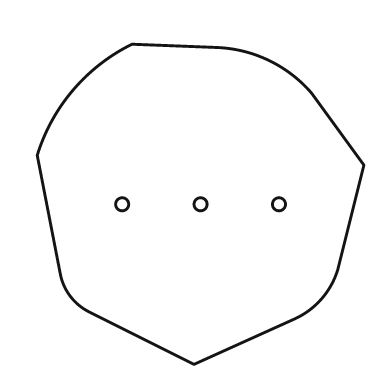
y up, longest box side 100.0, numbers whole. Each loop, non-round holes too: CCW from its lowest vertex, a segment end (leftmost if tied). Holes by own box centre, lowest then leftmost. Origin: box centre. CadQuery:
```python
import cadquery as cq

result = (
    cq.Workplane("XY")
    .moveTo(-2.0, -49.0)
    .lineTo(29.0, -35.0)
    .threePointArc((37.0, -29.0), (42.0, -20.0))
    .lineTo(50.0, 12.0)
    .lineTo(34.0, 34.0)
    .threePointArc((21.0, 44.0), (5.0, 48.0))
    .lineTo(-21.0, 49.0)
    .threePointArc((-39.0, 35.0), (-50.0, 15.0))
    .lineTo(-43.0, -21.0)
    .threePointArc((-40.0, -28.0), (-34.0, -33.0))
    .close()
    .moveTo(-24.0, 0.0)
    .circle(2.0)
    .moveTo(0.0, 0.0)
    .circle(2.0)
    .moveTo(24.0, 0.0)
    .circle(2.0)
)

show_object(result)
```